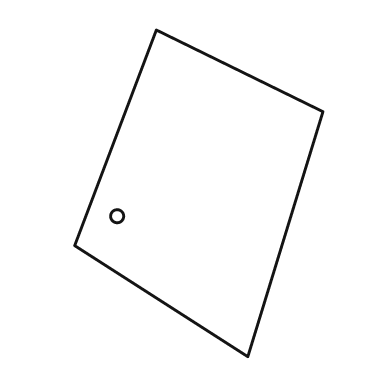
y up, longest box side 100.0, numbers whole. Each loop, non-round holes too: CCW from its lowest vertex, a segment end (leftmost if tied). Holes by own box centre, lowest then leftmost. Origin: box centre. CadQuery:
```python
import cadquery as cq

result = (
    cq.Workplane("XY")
    .moveTo(15.0, -50.0)
    .lineTo(38.0, 25.0)
    .lineTo(-13.0, 50.0)
    .lineTo(-38.0, -16.0)
    .close()
    .moveTo(-25.0, -7.0)
    .circle(2.0)
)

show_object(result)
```